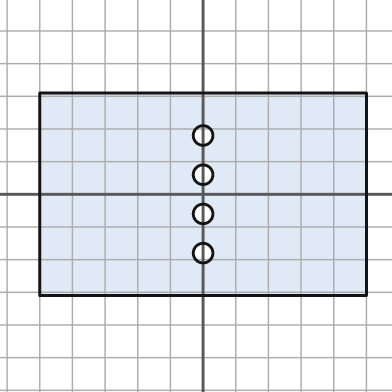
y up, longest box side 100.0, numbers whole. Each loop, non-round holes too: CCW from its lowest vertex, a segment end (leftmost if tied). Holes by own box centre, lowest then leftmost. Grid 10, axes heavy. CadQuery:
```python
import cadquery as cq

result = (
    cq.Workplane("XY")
    .moveTo(-50.0, -31.0)
    .lineTo(50.0, -31.0)
    .lineTo(50.0, 31.0)
    .lineTo(-50.0, 31.0)
    .close()
    .moveTo(0.0, -18.0)
    .circle(3.0)
    .moveTo(0.0, -6.0)
    .circle(3.0)
    .moveTo(0.0, 6.0)
    .circle(3.0)
    .moveTo(0.0, 18.0)
    .circle(3.0)
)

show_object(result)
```